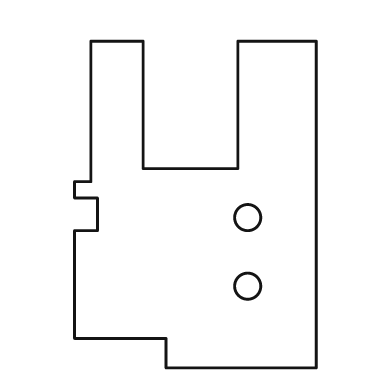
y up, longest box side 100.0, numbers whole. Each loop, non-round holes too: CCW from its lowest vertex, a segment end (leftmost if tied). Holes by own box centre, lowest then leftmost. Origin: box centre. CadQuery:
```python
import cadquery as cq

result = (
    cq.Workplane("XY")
    .moveTo(-9.0, -50.0)
    .lineTo(37.0, -50.0)
    .lineTo(37.0, 50.0)
    .lineTo(13.0, 50.0)
    .lineTo(13.0, 11.0)
    .lineTo(-16.0, 11.0)
    .lineTo(-16.0, 50.0)
    .lineTo(-32.0, 50.0)
    .lineTo(-32.0, 7.0)
    .lineTo(-37.0, 7.0)
    .lineTo(-37.0, 2.0)
    .lineTo(-30.0, 2.0)
    .lineTo(-30.0, -8.0)
    .lineTo(-37.0, -8.0)
    .lineTo(-37.0, -41.0)
    .lineTo(-9.0, -41.0)
    .close()
    .moveTo(16.0, -25.0)
    .circle(4.0)
    .moveTo(16.0, -4.0)
    .circle(4.0)
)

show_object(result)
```